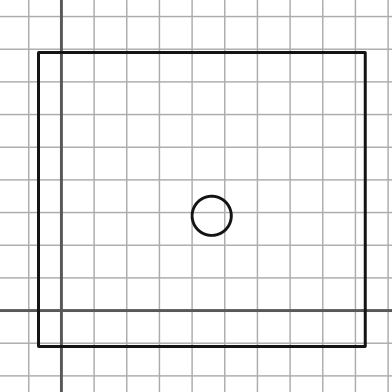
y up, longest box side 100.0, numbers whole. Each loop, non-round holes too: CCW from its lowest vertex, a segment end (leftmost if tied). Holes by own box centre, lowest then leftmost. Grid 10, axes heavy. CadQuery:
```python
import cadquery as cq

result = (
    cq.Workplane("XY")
    .moveTo(-7.0, -11.0)
    .lineTo(93.0, -11.0)
    .lineTo(93.0, 79.0)
    .lineTo(-7.0, 79.0)
    .close()
    .moveTo(46.0, 29.0)
    .circle(6.0)
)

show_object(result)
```